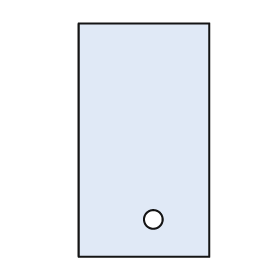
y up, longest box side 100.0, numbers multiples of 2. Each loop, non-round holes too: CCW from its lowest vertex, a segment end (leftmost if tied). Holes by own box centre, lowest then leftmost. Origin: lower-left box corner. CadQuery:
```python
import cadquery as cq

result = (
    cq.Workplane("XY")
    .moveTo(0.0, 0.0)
    .lineTo(56.0, 0.0)
    .lineTo(56.0, 100.0)
    .lineTo(0.0, 100.0)
    .close()
    .moveTo(32.0, 16.0)
    .circle(4.0)
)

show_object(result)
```